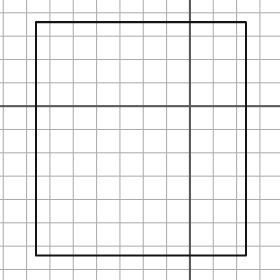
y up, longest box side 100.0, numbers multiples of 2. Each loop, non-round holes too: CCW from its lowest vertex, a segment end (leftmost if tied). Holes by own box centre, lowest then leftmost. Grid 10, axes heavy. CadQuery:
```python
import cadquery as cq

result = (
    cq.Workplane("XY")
    .moveTo(-66.0, -64.0)
    .lineTo(24.0, -64.0)
    .lineTo(24.0, 36.0)
    .lineTo(-66.0, 36.0)
    .close()
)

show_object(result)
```